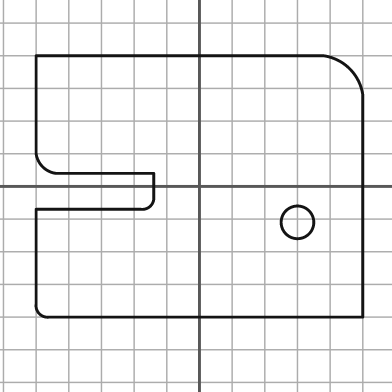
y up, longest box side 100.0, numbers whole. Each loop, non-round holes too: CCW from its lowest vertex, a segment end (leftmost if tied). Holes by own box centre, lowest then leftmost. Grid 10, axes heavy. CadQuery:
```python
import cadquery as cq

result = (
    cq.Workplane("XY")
    .moveTo(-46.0, -40.0)
    .lineTo(50.0, -40.0)
    .lineTo(50.0, 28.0)
    .threePointArc((46.0, 36.0), (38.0, 40.0))
    .lineTo(-50.0, 40.0)
    .lineTo(-50.0, 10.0)
    .threePointArc((-48.0, 6.0), (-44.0, 4.0))
    .lineTo(-14.0, 4.0)
    .lineTo(-14.0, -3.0)
    .threePointArc((-15.0, -6.0), (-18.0, -7.0))
    .lineTo(-50.0, -7.0)
    .lineTo(-50.0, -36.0)
    .threePointArc((-49.0, -39.0), (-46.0, -40.0))
    .close()
    .moveTo(30.0, -11.0)
    .circle(5.0)
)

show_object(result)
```